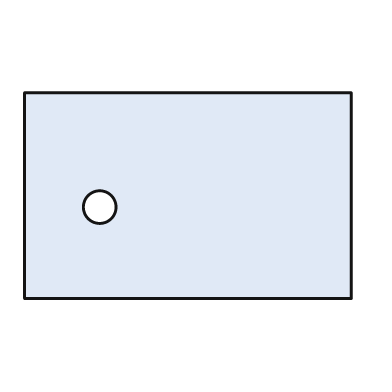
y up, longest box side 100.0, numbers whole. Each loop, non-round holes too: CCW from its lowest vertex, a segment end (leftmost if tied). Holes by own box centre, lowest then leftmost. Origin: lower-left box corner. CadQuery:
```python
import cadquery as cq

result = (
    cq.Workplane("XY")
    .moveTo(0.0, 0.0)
    .lineTo(100.0, 0.0)
    .lineTo(100.0, 63.0)
    .lineTo(0.0, 63.0)
    .close()
    .moveTo(23.0, 28.0)
    .circle(5.0)
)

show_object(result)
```